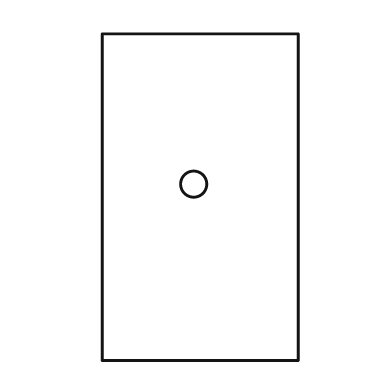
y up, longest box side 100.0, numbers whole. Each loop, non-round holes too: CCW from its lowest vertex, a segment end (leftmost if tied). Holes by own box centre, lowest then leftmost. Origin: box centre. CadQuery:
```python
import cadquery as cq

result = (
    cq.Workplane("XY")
    .moveTo(-30.0, -50.0)
    .lineTo(30.0, -50.0)
    .lineTo(30.0, 50.0)
    .lineTo(-30.0, 50.0)
    .close()
    .moveTo(-2.0, 4.0)
    .circle(4.0)
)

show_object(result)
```